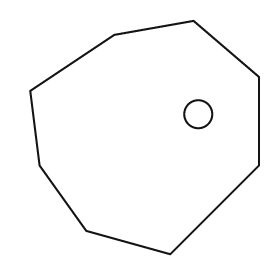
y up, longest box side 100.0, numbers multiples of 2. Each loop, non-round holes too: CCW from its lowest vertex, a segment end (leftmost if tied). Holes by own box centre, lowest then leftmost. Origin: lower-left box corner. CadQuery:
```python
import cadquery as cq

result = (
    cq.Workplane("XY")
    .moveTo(60.0, 0.0)
    .lineTo(98.0, 38.0)
    .lineTo(98.0, 76.0)
    .lineTo(70.0, 100.0)
    .lineTo(36.0, 94.0)
    .lineTo(0.0, 70.0)
    .lineTo(4.0, 38.0)
    .lineTo(24.0, 10.0)
    .close()
    .moveTo(72.0, 60.0)
    .circle(6.0)
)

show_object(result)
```